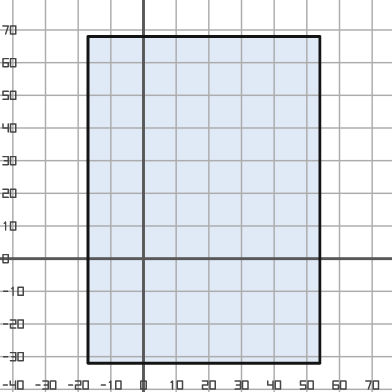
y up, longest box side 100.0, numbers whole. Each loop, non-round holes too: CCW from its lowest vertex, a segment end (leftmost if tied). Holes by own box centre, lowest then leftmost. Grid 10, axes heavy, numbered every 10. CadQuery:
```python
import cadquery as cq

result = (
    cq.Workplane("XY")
    .moveTo(-17.0, -32.0)
    .lineTo(54.0, -32.0)
    .lineTo(54.0, 68.0)
    .lineTo(-17.0, 68.0)
    .close()
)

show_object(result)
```